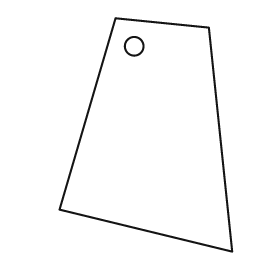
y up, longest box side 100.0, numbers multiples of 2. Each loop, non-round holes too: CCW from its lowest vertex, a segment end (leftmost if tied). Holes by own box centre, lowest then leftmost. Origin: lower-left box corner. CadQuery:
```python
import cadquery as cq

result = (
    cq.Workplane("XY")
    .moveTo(74.0, 0.0)
    .lineTo(64.0, 96.0)
    .lineTo(24.0, 100.0)
    .lineTo(0.0, 18.0)
    .close()
    .moveTo(32.0, 88.0)
    .circle(4.0)
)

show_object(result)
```